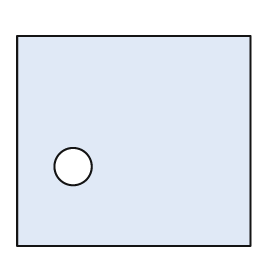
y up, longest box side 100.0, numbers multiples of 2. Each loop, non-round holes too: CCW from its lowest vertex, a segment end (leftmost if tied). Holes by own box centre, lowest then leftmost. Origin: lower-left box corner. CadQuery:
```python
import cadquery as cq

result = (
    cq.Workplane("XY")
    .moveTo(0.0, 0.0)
    .lineTo(100.0, 0.0)
    .lineTo(100.0, 90.0)
    .lineTo(0.0, 90.0)
    .close()
    .moveTo(24.0, 34.0)
    .circle(8.0)
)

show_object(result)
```